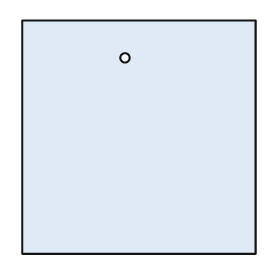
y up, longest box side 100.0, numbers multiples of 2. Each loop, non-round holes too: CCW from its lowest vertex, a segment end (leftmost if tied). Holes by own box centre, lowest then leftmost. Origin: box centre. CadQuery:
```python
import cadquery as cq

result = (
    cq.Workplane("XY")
    .moveTo(-50.0, -50.0)
    .lineTo(50.0, -50.0)
    .lineTo(50.0, 50.0)
    .lineTo(-50.0, 50.0)
    .close()
    .moveTo(-6.0, 34.0)
    .circle(2.0)
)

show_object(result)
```